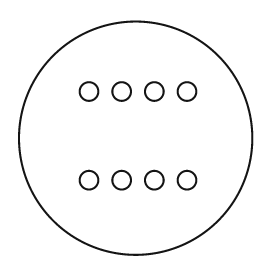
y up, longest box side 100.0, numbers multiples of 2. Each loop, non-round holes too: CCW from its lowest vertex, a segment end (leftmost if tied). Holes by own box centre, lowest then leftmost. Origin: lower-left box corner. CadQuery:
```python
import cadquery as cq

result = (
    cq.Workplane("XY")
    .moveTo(50.0, 50.0)
    .circle(50.0)
    .moveTo(30.0, 32.0)
    .circle(4.0)
    .moveTo(44.0, 32.0)
    .circle(4.0)
    .moveTo(58.0, 32.0)
    .circle(4.0)
    .moveTo(72.0, 32.0)
    .circle(4.0)
    .moveTo(30.0, 70.0)
    .circle(4.0)
    .moveTo(44.0, 70.0)
    .circle(4.0)
    .moveTo(58.0, 70.0)
    .circle(4.0)
    .moveTo(72.0, 70.0)
    .circle(4.0)
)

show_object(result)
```